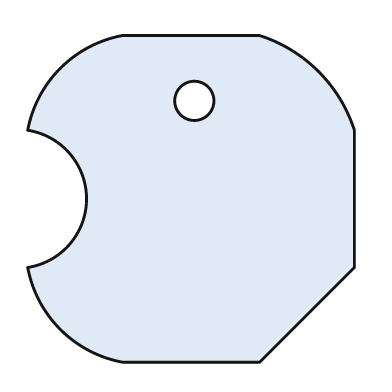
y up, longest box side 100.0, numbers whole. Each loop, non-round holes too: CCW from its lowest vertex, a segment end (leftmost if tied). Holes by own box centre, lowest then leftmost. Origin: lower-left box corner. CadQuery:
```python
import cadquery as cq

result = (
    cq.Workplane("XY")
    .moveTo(29.0, 0.0)
    .lineTo(71.0, 0.0)
    .lineTo(100.0, 29.0)
    .lineTo(100.0, 71.0)
    .threePointArc((89.0, 89.0), (71.0, 100.0))
    .lineTo(29.0, 100.0)
    .threePointArc((10.0, 90.0), (0.0, 71.0))
    .threePointArc((18.0, 50.0), (0.0, 29.0))
    .threePointArc((10.0, 10.0), (29.0, 0.0))
    .close()
    .moveTo(51.0, 80.0)
    .circle(6.0)
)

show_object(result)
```